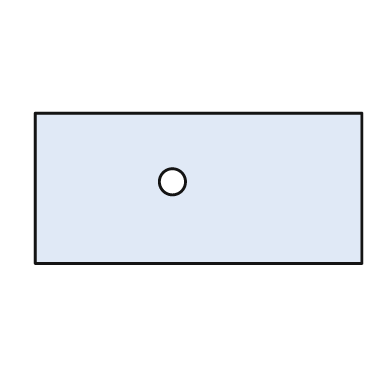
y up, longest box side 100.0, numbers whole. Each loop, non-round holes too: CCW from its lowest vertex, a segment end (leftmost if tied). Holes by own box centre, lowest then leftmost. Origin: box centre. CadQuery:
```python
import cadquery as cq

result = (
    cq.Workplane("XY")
    .moveTo(-50.0, -23.0)
    .lineTo(50.0, -23.0)
    .lineTo(50.0, 23.0)
    .lineTo(-50.0, 23.0)
    .close()
    .moveTo(-8.0, 2.0)
    .circle(4.0)
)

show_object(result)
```